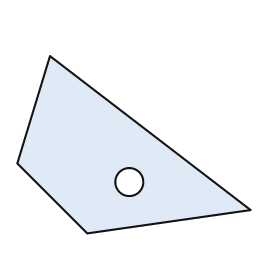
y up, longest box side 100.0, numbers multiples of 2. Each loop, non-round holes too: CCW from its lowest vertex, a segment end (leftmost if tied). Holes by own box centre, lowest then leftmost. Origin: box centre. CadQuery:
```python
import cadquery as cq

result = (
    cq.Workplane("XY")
    .moveTo(-20.0, -38.0)
    .lineTo(50.0, -28.0)
    .lineTo(-36.0, 38.0)
    .lineTo(-50.0, -8.0)
    .close()
    .moveTo(-2.0, -16.0)
    .circle(6.0)
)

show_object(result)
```